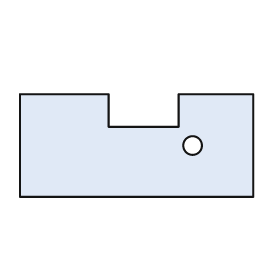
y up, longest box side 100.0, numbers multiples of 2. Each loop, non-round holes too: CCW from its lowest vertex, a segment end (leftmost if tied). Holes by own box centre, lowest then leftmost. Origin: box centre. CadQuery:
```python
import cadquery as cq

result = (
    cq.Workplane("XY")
    .moveTo(-50.0, -22.0)
    .lineTo(50.0, -22.0)
    .lineTo(50.0, 22.0)
    .lineTo(18.0, 22.0)
    .lineTo(18.0, 8.0)
    .lineTo(-12.0, 8.0)
    .lineTo(-12.0, 22.0)
    .lineTo(-50.0, 22.0)
    .close()
    .moveTo(24.0, 0.0)
    .circle(4.0)
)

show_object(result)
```